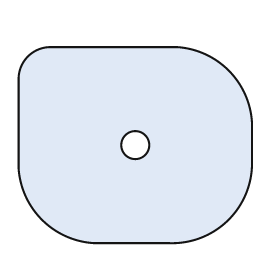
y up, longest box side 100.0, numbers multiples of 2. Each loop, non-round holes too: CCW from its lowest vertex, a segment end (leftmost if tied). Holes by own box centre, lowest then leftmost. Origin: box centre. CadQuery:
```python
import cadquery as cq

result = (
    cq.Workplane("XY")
    .moveTo(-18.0, -42.0)
    .lineTo(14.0, -42.0)
    .threePointArc((40.0, -32.0), (50.0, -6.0))
    .lineTo(50.0, 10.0)
    .threePointArc((40.0, 32.0), (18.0, 42.0))
    .lineTo(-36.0, 42.0)
    .threePointArc((-46.0, 38.0), (-50.0, 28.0))
    .lineTo(-50.0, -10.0)
    .threePointArc((-40.0, -32.0), (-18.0, -42.0))
    .close()
    .moveTo(0.0, 0.0)
    .circle(6.0)
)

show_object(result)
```